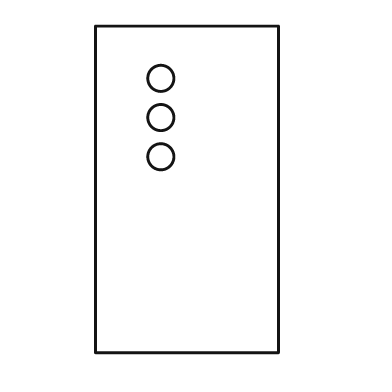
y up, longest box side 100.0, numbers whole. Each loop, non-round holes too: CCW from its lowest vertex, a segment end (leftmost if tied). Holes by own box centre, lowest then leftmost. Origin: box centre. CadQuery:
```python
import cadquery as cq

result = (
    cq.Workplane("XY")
    .moveTo(-28.0, -50.0)
    .lineTo(28.0, -50.0)
    .lineTo(28.0, 50.0)
    .lineTo(-28.0, 50.0)
    .close()
    .moveTo(-8.0, 10.0)
    .circle(4.0)
    .moveTo(-8.0, 22.0)
    .circle(4.0)
    .moveTo(-8.0, 34.0)
    .circle(4.0)
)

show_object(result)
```